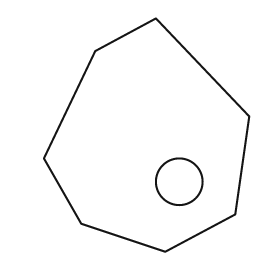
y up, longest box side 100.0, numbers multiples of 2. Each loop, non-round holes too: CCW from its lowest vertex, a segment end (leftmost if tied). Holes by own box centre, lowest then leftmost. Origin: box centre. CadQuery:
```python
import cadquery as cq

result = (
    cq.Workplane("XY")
    .moveTo(8.0, -50.0)
    .lineTo(38.0, -34.0)
    .lineTo(44.0, 8.0)
    .lineTo(4.0, 50.0)
    .lineTo(-22.0, 36.0)
    .lineTo(-44.0, -10.0)
    .lineTo(-28.0, -38.0)
    .close()
    .moveTo(14.0, -20.0)
    .circle(10.0)
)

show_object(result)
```